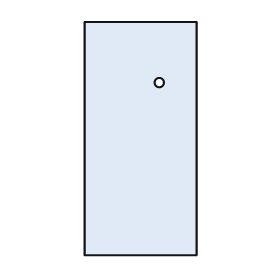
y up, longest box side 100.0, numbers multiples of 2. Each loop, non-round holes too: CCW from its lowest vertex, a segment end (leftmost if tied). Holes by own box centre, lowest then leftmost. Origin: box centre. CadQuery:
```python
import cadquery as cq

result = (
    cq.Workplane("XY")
    .moveTo(-24.0, -50.0)
    .lineTo(24.0, -50.0)
    .lineTo(24.0, 50.0)
    .lineTo(-24.0, 50.0)
    .close()
    .moveTo(8.0, 24.0)
    .circle(2.0)
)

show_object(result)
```